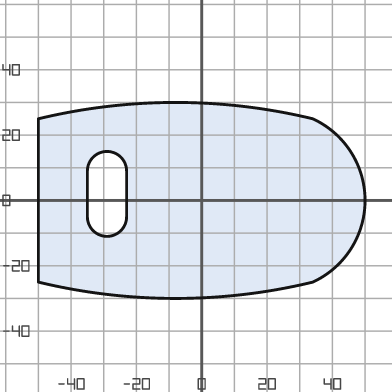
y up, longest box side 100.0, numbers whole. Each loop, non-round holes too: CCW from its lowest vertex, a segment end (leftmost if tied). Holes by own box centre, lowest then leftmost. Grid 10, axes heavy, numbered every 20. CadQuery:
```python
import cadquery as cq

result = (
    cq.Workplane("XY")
    .moveTo(-50.0, -25.0)
    .threePointArc((-8.0, -30.0), (34.0, -25.0))
    .threePointArc((50.0, 0.0), (34.0, 25.0))
    .threePointArc((-8.0, 30.0), (-50.0, 25.0))
    .close()
    .moveTo(-35.0, -5.0)
    .threePointArc((-29.0, -11.0), (-23.0, -5.0))
    .lineTo(-23.0, 9.0)
    .threePointArc((-29.0, 15.0), (-35.0, 9.0))
    .close()
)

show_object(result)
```